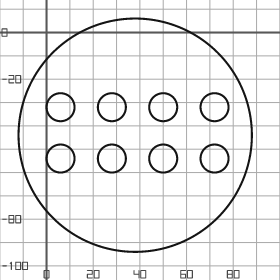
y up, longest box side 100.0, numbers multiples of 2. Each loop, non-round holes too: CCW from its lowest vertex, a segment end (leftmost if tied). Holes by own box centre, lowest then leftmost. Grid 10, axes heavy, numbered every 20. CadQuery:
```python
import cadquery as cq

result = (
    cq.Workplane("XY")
    .moveTo(38.0, -44.0)
    .circle(50.0)
    .moveTo(6.0, -54.0)
    .circle(6.0)
    .moveTo(28.0, -54.0)
    .circle(6.0)
    .moveTo(50.0, -54.0)
    .circle(6.0)
    .moveTo(72.0, -54.0)
    .circle(6.0)
    .moveTo(6.0, -32.0)
    .circle(6.0)
    .moveTo(28.0, -32.0)
    .circle(6.0)
    .moveTo(50.0, -32.0)
    .circle(6.0)
    .moveTo(72.0, -32.0)
    .circle(6.0)
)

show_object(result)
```